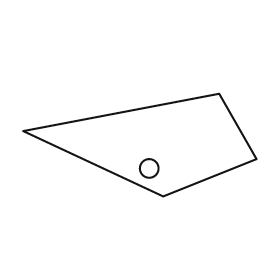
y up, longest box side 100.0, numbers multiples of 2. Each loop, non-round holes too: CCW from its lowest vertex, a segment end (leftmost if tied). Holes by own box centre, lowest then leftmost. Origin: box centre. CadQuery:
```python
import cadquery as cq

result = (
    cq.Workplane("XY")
    .moveTo(10.0, -22.0)
    .lineTo(50.0, -6.0)
    .lineTo(34.0, 22.0)
    .lineTo(-50.0, 6.0)
    .close()
    .moveTo(4.0, -10.0)
    .circle(4.0)
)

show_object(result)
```